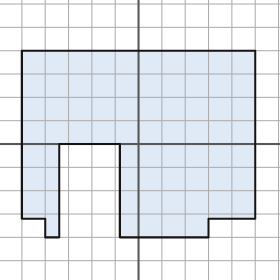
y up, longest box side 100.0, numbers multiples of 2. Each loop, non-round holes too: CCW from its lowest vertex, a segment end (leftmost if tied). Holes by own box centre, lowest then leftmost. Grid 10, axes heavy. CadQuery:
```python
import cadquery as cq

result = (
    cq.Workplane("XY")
    .moveTo(-40.0, -40.0)
    .lineTo(-34.0, -40.0)
    .lineTo(-34.0, 0.0)
    .lineTo(-8.0, 0.0)
    .lineTo(-8.0, -40.0)
    .lineTo(30.0, -40.0)
    .lineTo(30.0, -32.0)
    .lineTo(50.0, -32.0)
    .lineTo(50.0, 40.0)
    .lineTo(-50.0, 40.0)
    .lineTo(-50.0, -32.0)
    .lineTo(-40.0, -32.0)
    .close()
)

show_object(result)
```